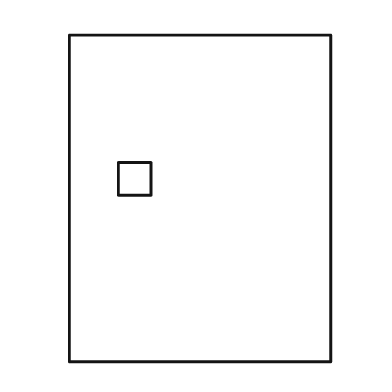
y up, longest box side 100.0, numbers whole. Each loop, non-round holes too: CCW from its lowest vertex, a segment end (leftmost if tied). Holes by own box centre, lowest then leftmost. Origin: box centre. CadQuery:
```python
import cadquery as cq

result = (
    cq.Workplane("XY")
    .moveTo(-40.0, -50.0)
    .lineTo(40.0, -50.0)
    .lineTo(40.0, 50.0)
    .lineTo(-40.0, 50.0)
    .close()
    .moveTo(-25.0, 1.0)
    .lineTo(-15.0, 1.0)
    .lineTo(-15.0, 11.0)
    .lineTo(-25.0, 11.0)
    .close()
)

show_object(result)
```